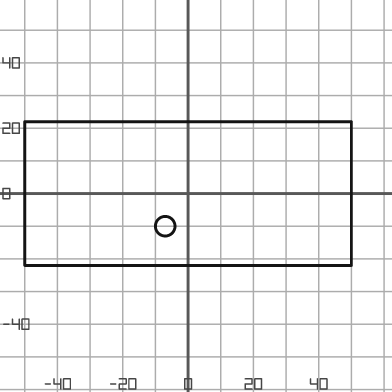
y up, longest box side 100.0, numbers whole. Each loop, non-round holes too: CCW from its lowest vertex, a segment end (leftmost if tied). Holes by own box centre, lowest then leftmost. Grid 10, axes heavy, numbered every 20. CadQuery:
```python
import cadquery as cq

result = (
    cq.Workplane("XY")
    .moveTo(-50.0, -22.0)
    .lineTo(50.0, -22.0)
    .lineTo(50.0, 22.0)
    .lineTo(-50.0, 22.0)
    .close()
    .moveTo(-7.0, -10.0)
    .circle(3.0)
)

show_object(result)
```